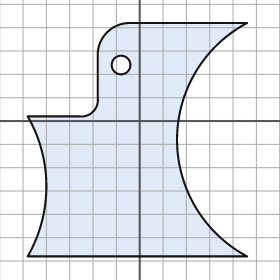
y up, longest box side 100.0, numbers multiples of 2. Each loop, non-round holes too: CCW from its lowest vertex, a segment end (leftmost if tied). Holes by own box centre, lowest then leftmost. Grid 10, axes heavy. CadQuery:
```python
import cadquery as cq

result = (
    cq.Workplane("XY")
    .moveTo(-48.0, -58.0)
    .lineTo(46.0, -58.0)
    .threePointArc((16.0, -8.0), (46.0, 42.0))
    .lineTo(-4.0, 42.0)
    .threePointArc((-14.0, 38.0), (-18.0, 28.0))
    .lineTo(-18.0, 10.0)
    .threePointArc((-20.0, 4.0), (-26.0, 2.0))
    .lineTo(-48.0, 2.0)
    .threePointArc((-40.0, -28.0), (-48.0, -58.0))
    .close()
    .moveTo(-8.0, 24.0)
    .circle(4.0)
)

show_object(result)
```